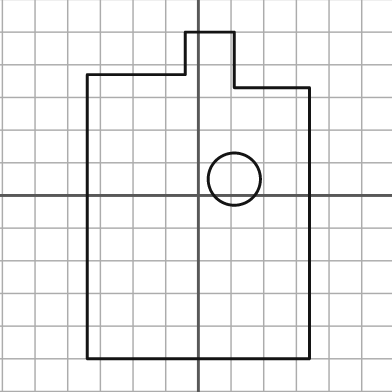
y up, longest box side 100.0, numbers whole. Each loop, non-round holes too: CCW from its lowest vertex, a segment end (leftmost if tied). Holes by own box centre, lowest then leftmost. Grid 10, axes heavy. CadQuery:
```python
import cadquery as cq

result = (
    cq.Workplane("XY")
    .moveTo(-34.0, -50.0)
    .lineTo(34.0, -50.0)
    .lineTo(34.0, 33.0)
    .lineTo(11.0, 33.0)
    .lineTo(11.0, 50.0)
    .lineTo(-4.0, 50.0)
    .lineTo(-4.0, 37.0)
    .lineTo(-34.0, 37.0)
    .close()
    .moveTo(11.0, 5.0)
    .circle(8.0)
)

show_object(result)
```